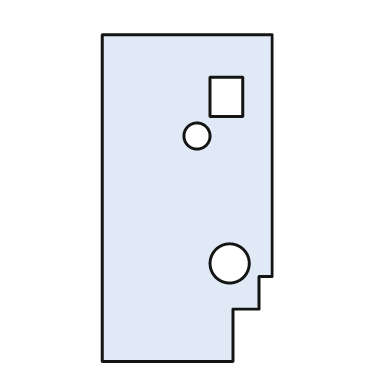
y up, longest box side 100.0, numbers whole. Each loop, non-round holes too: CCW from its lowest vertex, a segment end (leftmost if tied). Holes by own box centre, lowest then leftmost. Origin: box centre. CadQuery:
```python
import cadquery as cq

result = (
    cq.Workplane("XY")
    .moveTo(-26.0, -50.0)
    .lineTo(14.0, -50.0)
    .lineTo(14.0, -34.0)
    .lineTo(22.0, -34.0)
    .lineTo(22.0, -24.0)
    .lineTo(26.0, -24.0)
    .lineTo(26.0, 50.0)
    .lineTo(-26.0, 50.0)
    .close()
    .moveTo(13.0, -20.0)
    .circle(6.0)
    .moveTo(3.0, 19.0)
    .circle(4.0)
    .moveTo(7.0, 25.0)
    .lineTo(17.0, 25.0)
    .lineTo(17.0, 37.0)
    .lineTo(7.0, 37.0)
    .close()
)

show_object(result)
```